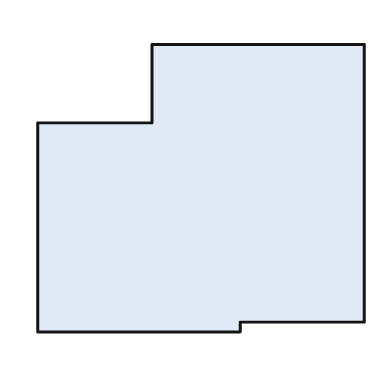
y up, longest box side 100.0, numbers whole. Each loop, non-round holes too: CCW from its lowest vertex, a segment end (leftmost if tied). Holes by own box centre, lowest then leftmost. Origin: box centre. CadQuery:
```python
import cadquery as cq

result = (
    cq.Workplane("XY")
    .moveTo(-50.0, -44.0)
    .lineTo(12.0, -44.0)
    .lineTo(12.0, -41.0)
    .lineTo(50.0, -41.0)
    .lineTo(50.0, 44.0)
    .lineTo(-15.0, 44.0)
    .lineTo(-15.0, 20.0)
    .lineTo(-50.0, 20.0)
    .close()
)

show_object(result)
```